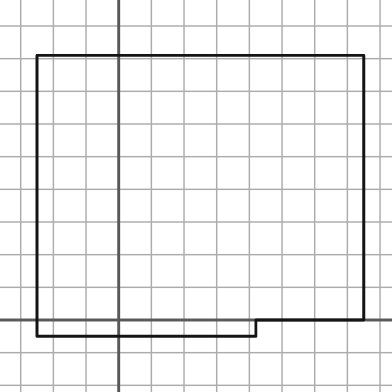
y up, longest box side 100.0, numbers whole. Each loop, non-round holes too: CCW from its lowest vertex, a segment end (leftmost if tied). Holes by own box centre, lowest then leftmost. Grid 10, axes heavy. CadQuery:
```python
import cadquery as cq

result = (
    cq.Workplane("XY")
    .moveTo(-25.0, -5.0)
    .lineTo(42.0, -5.0)
    .lineTo(42.0, 0.0)
    .lineTo(75.0, 0.0)
    .lineTo(75.0, 81.0)
    .lineTo(-25.0, 81.0)
    .close()
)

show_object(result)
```